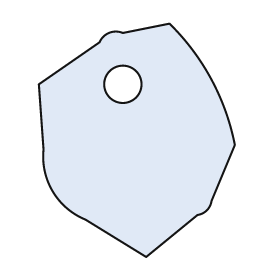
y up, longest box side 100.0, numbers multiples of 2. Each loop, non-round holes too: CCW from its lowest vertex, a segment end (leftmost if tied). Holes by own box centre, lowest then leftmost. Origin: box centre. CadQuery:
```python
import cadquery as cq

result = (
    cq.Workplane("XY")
    .moveTo(4.0, -50.0)
    .lineTo(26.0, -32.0)
    .threePointArc((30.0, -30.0), (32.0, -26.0))
    .lineTo(42.0, -2.0)
    .threePointArc((32.0, 26.0), (14.0, 50.0))
    .lineTo(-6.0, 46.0)
    .threePointArc((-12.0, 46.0), (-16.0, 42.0))
    .lineTo(-42.0, 24.0)
    .lineTo(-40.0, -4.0)
    .threePointArc((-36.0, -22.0), (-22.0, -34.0))
    .close()
    .moveTo(-6.0, 24.0)
    .circle(8.0)
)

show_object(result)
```